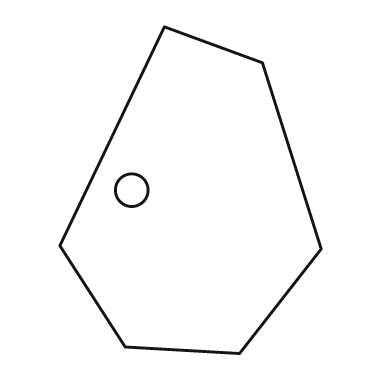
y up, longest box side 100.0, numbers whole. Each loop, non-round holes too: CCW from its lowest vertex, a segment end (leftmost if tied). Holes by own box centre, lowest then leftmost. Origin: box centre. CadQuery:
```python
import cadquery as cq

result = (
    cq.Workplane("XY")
    .moveTo(15.0, -50.0)
    .lineTo(40.0, -18.0)
    .lineTo(22.0, 39.0)
    .lineTo(-8.0, 50.0)
    .lineTo(-40.0, -17.0)
    .lineTo(-20.0, -48.0)
    .close()
    .moveTo(-18.0, 0.0)
    .circle(5.0)
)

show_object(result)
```